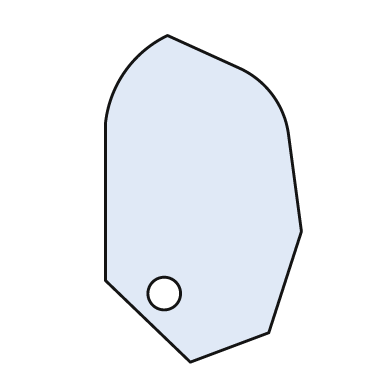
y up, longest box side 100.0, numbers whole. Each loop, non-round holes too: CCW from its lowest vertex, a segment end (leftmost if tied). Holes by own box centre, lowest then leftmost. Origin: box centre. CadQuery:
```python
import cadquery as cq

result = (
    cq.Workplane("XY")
    .moveTo(-4.0, -50.0)
    .lineTo(20.0, -41.0)
    .lineTo(30.0, -10.0)
    .lineTo(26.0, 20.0)
    .threePointArc((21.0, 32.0), (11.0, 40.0))
    .lineTo(-11.0, 50.0)
    .threePointArc((-24.0, 39.0), (-30.0, 23.0))
    .lineTo(-30.0, -25.0)
    .close()
    .moveTo(-12.0, -29.0)
    .circle(5.0)
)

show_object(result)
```